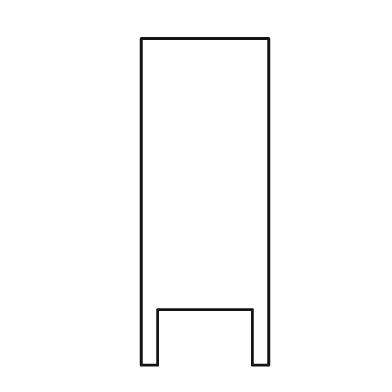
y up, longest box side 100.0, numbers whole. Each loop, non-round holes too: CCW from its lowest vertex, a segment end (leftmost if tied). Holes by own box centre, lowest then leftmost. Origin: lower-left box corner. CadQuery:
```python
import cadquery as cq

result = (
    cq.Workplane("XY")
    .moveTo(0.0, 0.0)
    .lineTo(5.0, 0.0)
    .lineTo(5.0, 17.0)
    .lineTo(34.0, 17.0)
    .lineTo(34.0, 0.0)
    .lineTo(39.0, 0.0)
    .lineTo(39.0, 100.0)
    .lineTo(0.0, 100.0)
    .close()
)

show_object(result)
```